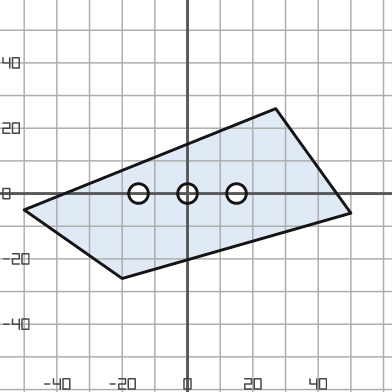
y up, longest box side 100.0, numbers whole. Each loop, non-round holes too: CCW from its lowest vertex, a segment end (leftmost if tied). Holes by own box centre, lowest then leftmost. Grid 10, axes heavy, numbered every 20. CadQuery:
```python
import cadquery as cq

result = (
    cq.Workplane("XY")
    .moveTo(-20.0, -26.0)
    .lineTo(50.0, -6.0)
    .lineTo(27.0, 26.0)
    .lineTo(-50.0, -5.0)
    .close()
    .moveTo(-15.0, 0.0)
    .circle(3.0)
    .moveTo(0.0, 0.0)
    .circle(3.0)
    .moveTo(15.0, 0.0)
    .circle(3.0)
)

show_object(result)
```